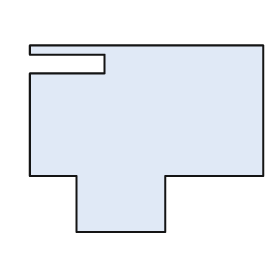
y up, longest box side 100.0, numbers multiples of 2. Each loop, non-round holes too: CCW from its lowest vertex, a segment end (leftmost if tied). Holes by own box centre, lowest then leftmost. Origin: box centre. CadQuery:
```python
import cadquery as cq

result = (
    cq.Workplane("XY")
    .moveTo(-30.0, -40.0)
    .lineTo(8.0, -40.0)
    .lineTo(8.0, -16.0)
    .lineTo(50.0, -16.0)
    .lineTo(50.0, 40.0)
    .lineTo(-50.0, 40.0)
    .lineTo(-50.0, 36.0)
    .lineTo(-18.0, 36.0)
    .lineTo(-18.0, 28.0)
    .lineTo(-50.0, 28.0)
    .lineTo(-50.0, -16.0)
    .lineTo(-30.0, -16.0)
    .close()
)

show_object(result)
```